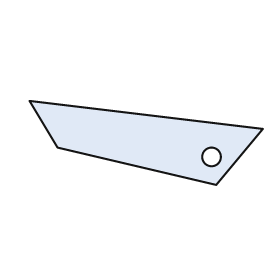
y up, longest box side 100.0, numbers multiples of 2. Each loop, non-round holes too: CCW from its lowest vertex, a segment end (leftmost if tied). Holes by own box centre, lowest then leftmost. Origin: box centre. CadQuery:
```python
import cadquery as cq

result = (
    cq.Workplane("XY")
    .moveTo(30.0, -18.0)
    .lineTo(50.0, 6.0)
    .lineTo(-50.0, 18.0)
    .lineTo(-38.0, -2.0)
    .close()
    .moveTo(28.0, -6.0)
    .circle(4.0)
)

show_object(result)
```